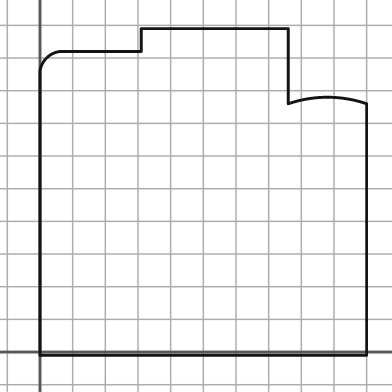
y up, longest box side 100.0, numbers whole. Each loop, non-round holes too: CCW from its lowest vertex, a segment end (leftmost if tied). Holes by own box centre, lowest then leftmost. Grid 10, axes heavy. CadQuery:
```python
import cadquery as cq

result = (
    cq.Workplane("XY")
    .moveTo(0.0, -1.0)
    .lineTo(100.0, -1.0)
    .lineTo(100.0, 76.0)
    .threePointArc((88.0, 78.0), (76.0, 76.0))
    .lineTo(76.0, 99.0)
    .lineTo(31.0, 99.0)
    .lineTo(31.0, 92.0)
    .lineTo(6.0, 92.0)
    .threePointArc((2.0, 90.0), (0.0, 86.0))
    .close()
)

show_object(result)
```